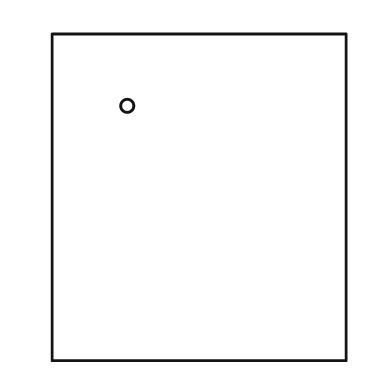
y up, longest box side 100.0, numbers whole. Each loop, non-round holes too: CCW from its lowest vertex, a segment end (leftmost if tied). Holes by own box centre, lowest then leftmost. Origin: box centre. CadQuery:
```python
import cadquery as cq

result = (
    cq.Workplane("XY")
    .moveTo(-45.0, -50.0)
    .lineTo(45.0, -50.0)
    .lineTo(45.0, 50.0)
    .lineTo(-45.0, 50.0)
    .close()
    .moveTo(-22.0, 28.0)
    .circle(2.0)
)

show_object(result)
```